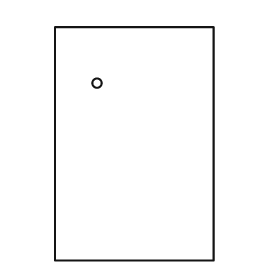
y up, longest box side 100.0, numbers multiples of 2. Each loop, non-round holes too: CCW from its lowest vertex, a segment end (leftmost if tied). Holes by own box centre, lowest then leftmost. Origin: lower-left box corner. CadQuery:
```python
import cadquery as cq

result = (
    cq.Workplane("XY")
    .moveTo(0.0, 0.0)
    .lineTo(68.0, 0.0)
    .lineTo(68.0, 100.0)
    .lineTo(0.0, 100.0)
    .close()
    .moveTo(18.0, 76.0)
    .circle(2.0)
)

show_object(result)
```